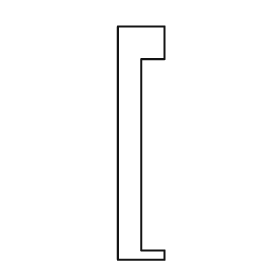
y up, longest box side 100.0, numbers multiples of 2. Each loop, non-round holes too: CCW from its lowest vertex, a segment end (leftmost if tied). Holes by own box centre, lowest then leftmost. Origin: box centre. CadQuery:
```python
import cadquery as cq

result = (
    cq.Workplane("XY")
    .moveTo(-10.0, -50.0)
    .lineTo(10.0, -50.0)
    .lineTo(10.0, -46.0)
    .lineTo(0.0, -46.0)
    .lineTo(0.0, 36.0)
    .lineTo(10.0, 36.0)
    .lineTo(10.0, 50.0)
    .lineTo(-10.0, 50.0)
    .close()
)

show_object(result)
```